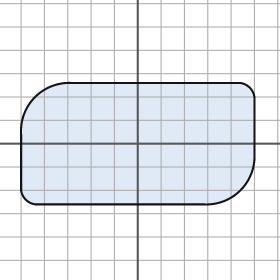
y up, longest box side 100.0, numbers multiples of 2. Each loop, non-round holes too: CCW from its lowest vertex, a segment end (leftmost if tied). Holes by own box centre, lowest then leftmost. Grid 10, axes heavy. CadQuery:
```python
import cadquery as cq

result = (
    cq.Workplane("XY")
    .moveTo(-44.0, -26.0)
    .lineTo(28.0, -26.0)
    .threePointArc((44.0, -20.0), (50.0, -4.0))
    .lineTo(50.0, 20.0)
    .threePointArc((48.0, 24.0), (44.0, 26.0))
    .lineTo(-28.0, 26.0)
    .threePointArc((-44.0, 20.0), (-50.0, 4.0))
    .lineTo(-50.0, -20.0)
    .threePointArc((-48.0, -24.0), (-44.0, -26.0))
    .close()
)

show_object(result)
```